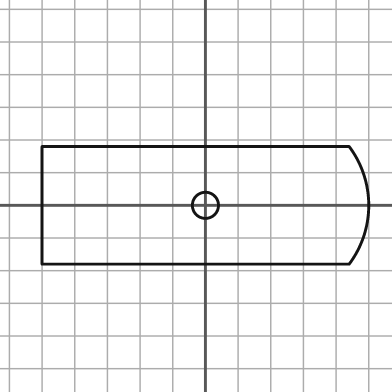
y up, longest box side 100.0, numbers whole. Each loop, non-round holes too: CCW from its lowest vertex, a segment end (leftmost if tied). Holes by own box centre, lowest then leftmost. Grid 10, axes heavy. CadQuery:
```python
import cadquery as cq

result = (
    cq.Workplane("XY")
    .moveTo(-50.0, -18.0)
    .lineTo(44.0, -18.0)
    .threePointArc((50.0, 0.0), (44.0, 18.0))
    .lineTo(-50.0, 18.0)
    .close()
    .moveTo(0.0, 0.0)
    .circle(4.0)
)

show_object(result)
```